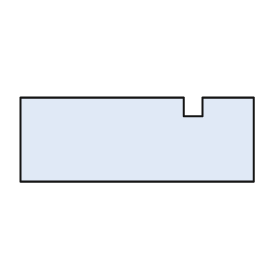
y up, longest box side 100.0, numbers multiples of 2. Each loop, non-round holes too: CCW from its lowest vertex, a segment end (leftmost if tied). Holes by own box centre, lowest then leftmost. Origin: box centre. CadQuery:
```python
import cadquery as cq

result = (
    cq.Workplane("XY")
    .moveTo(-50.0, -18.0)
    .lineTo(50.0, -18.0)
    .lineTo(50.0, 18.0)
    .lineTo(28.0, 18.0)
    .lineTo(28.0, 10.0)
    .lineTo(20.0, 10.0)
    .lineTo(20.0, 18.0)
    .lineTo(-50.0, 18.0)
    .close()
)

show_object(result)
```